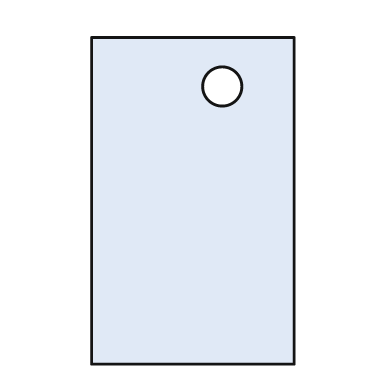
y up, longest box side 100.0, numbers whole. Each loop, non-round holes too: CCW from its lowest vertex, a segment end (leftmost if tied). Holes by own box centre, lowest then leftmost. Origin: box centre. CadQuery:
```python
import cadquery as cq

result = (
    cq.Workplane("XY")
    .moveTo(-31.0, -50.0)
    .lineTo(31.0, -50.0)
    .lineTo(31.0, 50.0)
    .lineTo(-31.0, 50.0)
    .close()
    .moveTo(9.0, 35.0)
    .circle(6.0)
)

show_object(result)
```